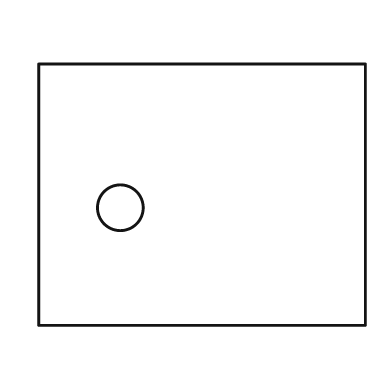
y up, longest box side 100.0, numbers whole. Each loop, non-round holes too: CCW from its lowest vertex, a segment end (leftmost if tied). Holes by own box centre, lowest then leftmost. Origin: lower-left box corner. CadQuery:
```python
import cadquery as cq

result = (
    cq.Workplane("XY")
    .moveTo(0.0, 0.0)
    .lineTo(100.0, 0.0)
    .lineTo(100.0, 80.0)
    .lineTo(0.0, 80.0)
    .close()
    .moveTo(25.0, 36.0)
    .circle(7.0)
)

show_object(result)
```